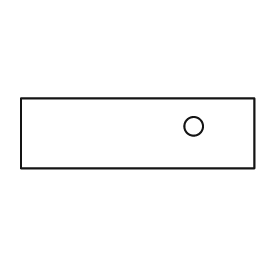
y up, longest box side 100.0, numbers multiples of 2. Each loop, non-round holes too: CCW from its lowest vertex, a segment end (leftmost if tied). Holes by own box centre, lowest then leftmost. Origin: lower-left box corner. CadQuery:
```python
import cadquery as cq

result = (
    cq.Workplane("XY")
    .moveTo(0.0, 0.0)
    .lineTo(100.0, 0.0)
    .lineTo(100.0, 30.0)
    .lineTo(0.0, 30.0)
    .close()
    .moveTo(74.0, 18.0)
    .circle(4.0)
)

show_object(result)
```